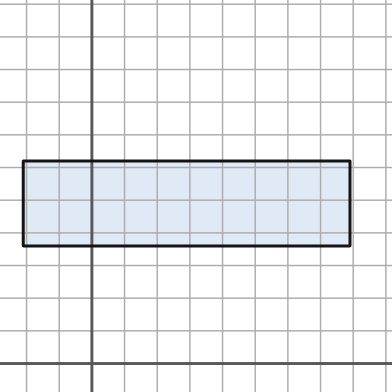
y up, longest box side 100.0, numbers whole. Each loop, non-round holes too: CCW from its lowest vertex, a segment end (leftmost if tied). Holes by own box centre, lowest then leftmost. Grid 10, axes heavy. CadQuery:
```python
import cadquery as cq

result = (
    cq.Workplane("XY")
    .moveTo(-21.0, 36.0)
    .lineTo(79.0, 36.0)
    .lineTo(79.0, 62.0)
    .lineTo(-21.0, 62.0)
    .close()
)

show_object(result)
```